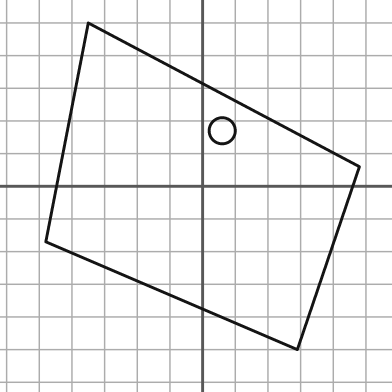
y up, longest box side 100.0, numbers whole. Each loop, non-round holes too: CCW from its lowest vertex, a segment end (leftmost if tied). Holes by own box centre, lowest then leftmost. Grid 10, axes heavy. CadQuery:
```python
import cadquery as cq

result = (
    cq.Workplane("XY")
    .moveTo(29.0, -50.0)
    .lineTo(48.0, 6.0)
    .lineTo(-35.0, 50.0)
    .lineTo(-48.0, -17.0)
    .close()
    .moveTo(6.0, 17.0)
    .circle(4.0)
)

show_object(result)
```